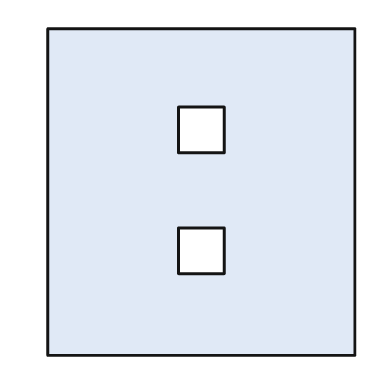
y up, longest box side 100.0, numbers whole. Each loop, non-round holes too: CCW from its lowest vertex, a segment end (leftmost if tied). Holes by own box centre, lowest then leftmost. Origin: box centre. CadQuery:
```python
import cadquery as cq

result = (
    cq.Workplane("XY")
    .moveTo(-47.0, -50.0)
    .lineTo(47.0, -50.0)
    .lineTo(47.0, 50.0)
    .lineTo(-47.0, 50.0)
    .close()
    .moveTo(-7.0, -25.0)
    .lineTo(7.0, -25.0)
    .lineTo(7.0, -11.0)
    .lineTo(-7.0, -11.0)
    .close()
    .moveTo(-7.0, 12.0)
    .lineTo(7.0, 12.0)
    .lineTo(7.0, 26.0)
    .lineTo(-7.0, 26.0)
    .close()
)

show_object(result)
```